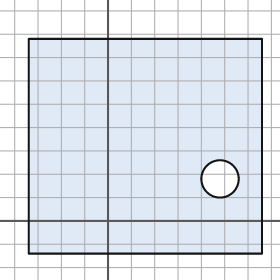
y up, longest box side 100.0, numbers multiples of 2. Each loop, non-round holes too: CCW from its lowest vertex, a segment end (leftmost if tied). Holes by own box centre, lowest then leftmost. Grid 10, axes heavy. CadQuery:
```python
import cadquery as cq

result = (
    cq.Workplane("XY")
    .moveTo(-34.0, -14.0)
    .lineTo(66.0, -14.0)
    .lineTo(66.0, 78.0)
    .lineTo(-34.0, 78.0)
    .close()
    .moveTo(48.0, 18.0)
    .circle(8.0)
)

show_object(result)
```